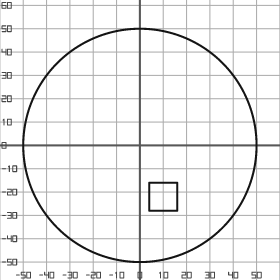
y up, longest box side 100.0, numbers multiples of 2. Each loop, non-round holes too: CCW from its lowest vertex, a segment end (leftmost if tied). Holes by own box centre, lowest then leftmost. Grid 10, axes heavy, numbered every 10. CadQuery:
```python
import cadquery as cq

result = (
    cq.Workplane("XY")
    .moveTo(0.0, 0.0)
    .circle(50.0)
    .moveTo(4.0, -28.0)
    .lineTo(16.0, -28.0)
    .lineTo(16.0, -16.0)
    .lineTo(4.0, -16.0)
    .close()
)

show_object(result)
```